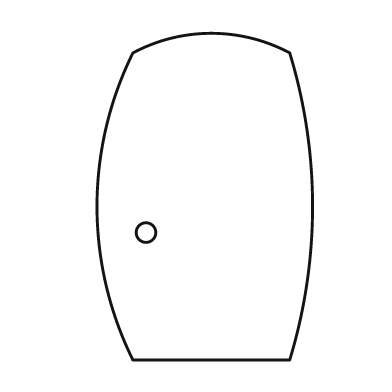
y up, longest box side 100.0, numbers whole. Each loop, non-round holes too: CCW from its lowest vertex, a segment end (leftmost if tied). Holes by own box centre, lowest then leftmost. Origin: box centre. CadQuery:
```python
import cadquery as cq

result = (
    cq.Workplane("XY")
    .moveTo(-22.0, -50.0)
    .lineTo(26.0, -50.0)
    .threePointArc((33.0, -3.0), (26.0, 44.0))
    .threePointArc((2.0, 50.0), (-22.0, 44.0))
    .threePointArc((-33.0, -3.0), (-22.0, -50.0))
    .close()
    .moveTo(-18.0, -11.0)
    .circle(3.0)
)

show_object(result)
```